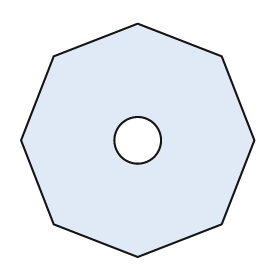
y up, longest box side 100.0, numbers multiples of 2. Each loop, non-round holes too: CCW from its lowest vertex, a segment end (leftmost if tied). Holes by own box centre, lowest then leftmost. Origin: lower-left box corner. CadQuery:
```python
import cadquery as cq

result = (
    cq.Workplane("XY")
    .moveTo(50.0, 0.0)
    .lineTo(86.0, 14.0)
    .lineTo(100.0, 50.0)
    .lineTo(86.0, 86.0)
    .lineTo(50.0, 100.0)
    .lineTo(14.0, 86.0)
    .lineTo(0.0, 50.0)
    .lineTo(14.0, 14.0)
    .close()
    .moveTo(50.0, 50.0)
    .circle(10.0)
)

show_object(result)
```